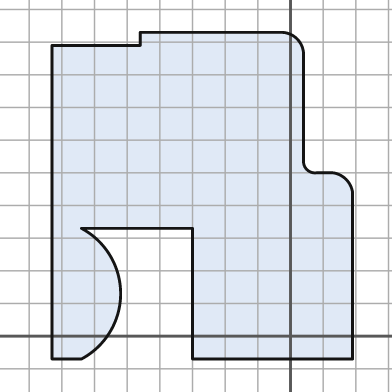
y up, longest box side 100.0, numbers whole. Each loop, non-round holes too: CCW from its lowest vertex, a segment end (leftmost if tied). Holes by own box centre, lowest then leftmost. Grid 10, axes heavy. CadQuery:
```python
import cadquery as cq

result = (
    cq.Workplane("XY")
    .moveTo(-73.0, -7.0)
    .lineTo(-64.0, -7.0)
    .threePointArc((-52.0, 13.0), (-64.0, 33.0))
    .lineTo(-30.0, 33.0)
    .lineTo(-30.0, -7.0)
    .lineTo(19.0, -7.0)
    .lineTo(19.0, 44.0)
    .threePointArc((17.0, 48.0), (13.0, 50.0))
    .lineTo(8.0, 50.0)
    .threePointArc((5.0, 51.0), (4.0, 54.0))
    .lineTo(4.0, 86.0)
    .threePointArc((2.0, 91.0), (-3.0, 93.0))
    .lineTo(-46.0, 93.0)
    .lineTo(-46.0, 89.0)
    .lineTo(-73.0, 89.0)
    .close()
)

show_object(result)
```